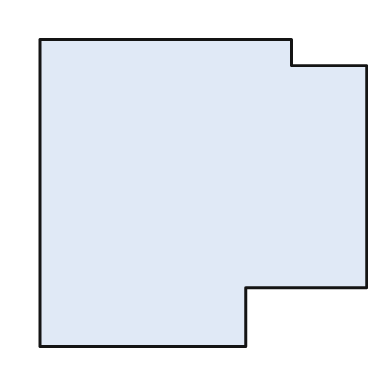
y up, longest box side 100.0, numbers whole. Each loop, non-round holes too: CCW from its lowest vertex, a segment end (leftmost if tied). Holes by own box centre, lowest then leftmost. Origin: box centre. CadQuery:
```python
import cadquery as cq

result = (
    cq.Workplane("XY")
    .moveTo(-50.0, -47.0)
    .lineTo(13.0, -47.0)
    .lineTo(13.0, -29.0)
    .lineTo(50.0, -29.0)
    .lineTo(50.0, 39.0)
    .lineTo(27.0, 39.0)
    .lineTo(27.0, 47.0)
    .lineTo(-50.0, 47.0)
    .close()
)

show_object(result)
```